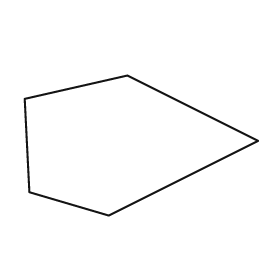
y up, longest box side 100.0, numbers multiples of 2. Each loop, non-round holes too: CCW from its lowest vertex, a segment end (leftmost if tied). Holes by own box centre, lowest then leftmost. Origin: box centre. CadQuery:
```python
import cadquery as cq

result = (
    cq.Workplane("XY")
    .moveTo(-14.0, -30.0)
    .lineTo(50.0, 2.0)
    .lineTo(-6.0, 30.0)
    .lineTo(-50.0, 20.0)
    .lineTo(-48.0, -20.0)
    .close()
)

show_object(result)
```